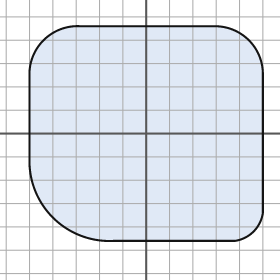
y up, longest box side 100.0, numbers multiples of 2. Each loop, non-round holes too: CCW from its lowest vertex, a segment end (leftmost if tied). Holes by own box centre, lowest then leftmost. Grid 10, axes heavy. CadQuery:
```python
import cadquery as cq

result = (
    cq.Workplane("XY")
    .moveTo(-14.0, -46.0)
    .lineTo(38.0, -46.0)
    .threePointArc((46.0, -42.0), (50.0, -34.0))
    .lineTo(50.0, 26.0)
    .threePointArc((44.0, 40.0), (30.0, 46.0))
    .lineTo(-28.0, 46.0)
    .threePointArc((-44.0, 40.0), (-50.0, 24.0))
    .lineTo(-50.0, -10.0)
    .threePointArc((-40.0, -36.0), (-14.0, -46.0))
    .close()
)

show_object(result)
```